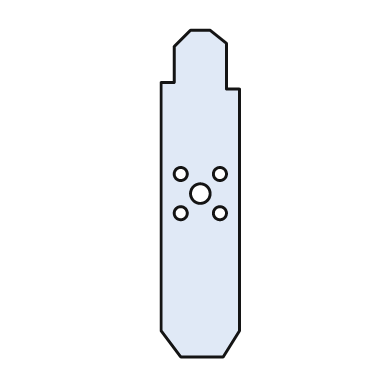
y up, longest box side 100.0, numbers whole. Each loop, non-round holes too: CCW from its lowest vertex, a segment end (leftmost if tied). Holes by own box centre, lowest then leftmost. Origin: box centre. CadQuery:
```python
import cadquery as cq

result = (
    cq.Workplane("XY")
    .moveTo(-6.0, -50.0)
    .lineTo(7.0, -50.0)
    .lineTo(12.0, -42.0)
    .lineTo(12.0, 32.0)
    .lineTo(8.0, 32.0)
    .lineTo(8.0, 46.0)
    .lineTo(3.0, 50.0)
    .lineTo(-3.0, 50.0)
    .lineTo(-8.0, 45.0)
    .lineTo(-8.0, 34.0)
    .lineTo(-12.0, 34.0)
    .lineTo(-12.0, -42.0)
    .close()
    .moveTo(-6.0, -6.0)
    .circle(2.0)
    .moveTo(6.0, -6.0)
    .circle(2.0)
    .moveTo(0.0, 0.0)
    .circle(3.0)
    .moveTo(-6.0, 6.0)
    .circle(2.0)
    .moveTo(6.0, 6.0)
    .circle(2.0)
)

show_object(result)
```